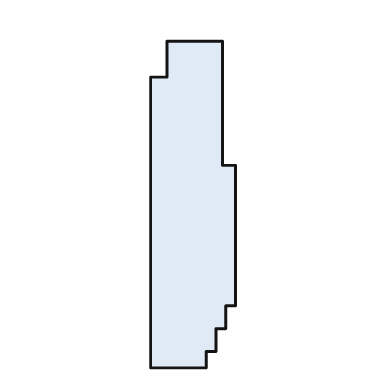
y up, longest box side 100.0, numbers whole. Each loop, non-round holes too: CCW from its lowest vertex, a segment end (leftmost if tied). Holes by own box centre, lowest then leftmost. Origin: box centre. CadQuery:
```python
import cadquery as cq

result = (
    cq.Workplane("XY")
    .moveTo(-13.0, -50.0)
    .lineTo(4.0, -50.0)
    .lineTo(4.0, -45.0)
    .lineTo(7.0, -45.0)
    .lineTo(7.0, -38.0)
    .lineTo(10.0, -38.0)
    .lineTo(10.0, -31.0)
    .lineTo(13.0, -31.0)
    .lineTo(13.0, 12.0)
    .lineTo(9.0, 12.0)
    .lineTo(9.0, 50.0)
    .lineTo(-8.0, 50.0)
    .lineTo(-8.0, 39.0)
    .lineTo(-13.0, 39.0)
    .close()
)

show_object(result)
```